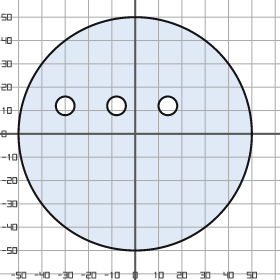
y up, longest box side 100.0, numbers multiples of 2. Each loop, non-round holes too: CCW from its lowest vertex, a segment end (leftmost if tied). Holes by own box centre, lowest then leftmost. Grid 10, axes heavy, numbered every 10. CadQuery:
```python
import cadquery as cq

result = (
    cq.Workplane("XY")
    .moveTo(0.0, 0.0)
    .circle(50.0)
    .moveTo(-30.0, 12.0)
    .circle(4.0)
    .moveTo(-8.0, 12.0)
    .circle(4.0)
    .moveTo(14.0, 12.0)
    .circle(4.0)
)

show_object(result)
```